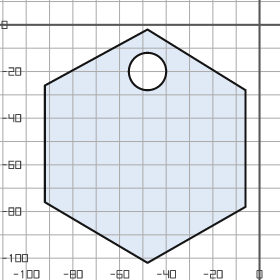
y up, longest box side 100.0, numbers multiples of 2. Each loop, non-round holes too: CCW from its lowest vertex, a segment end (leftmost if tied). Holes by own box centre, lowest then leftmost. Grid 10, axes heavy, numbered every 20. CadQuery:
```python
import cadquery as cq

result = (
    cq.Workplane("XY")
    .moveTo(-48.0, -102.0)
    .lineTo(-6.0, -78.0)
    .lineTo(-6.0, -28.0)
    .lineTo(-48.0, -2.0)
    .lineTo(-92.0, -26.0)
    .lineTo(-92.0, -76.0)
    .close()
    .moveTo(-48.0, -20.0)
    .circle(8.0)
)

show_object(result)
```